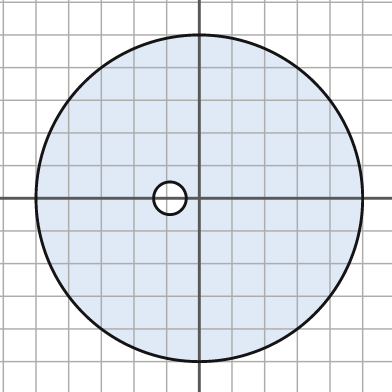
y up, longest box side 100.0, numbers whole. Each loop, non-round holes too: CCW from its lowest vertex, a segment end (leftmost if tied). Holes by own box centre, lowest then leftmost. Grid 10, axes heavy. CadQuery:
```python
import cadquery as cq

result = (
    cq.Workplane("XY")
    .moveTo(0.0, 0.0)
    .circle(50.0)
    .moveTo(-9.0, 0.0)
    .circle(5.0)
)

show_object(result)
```